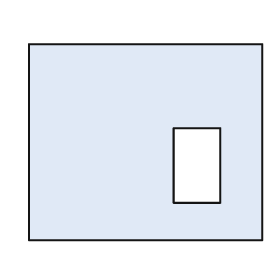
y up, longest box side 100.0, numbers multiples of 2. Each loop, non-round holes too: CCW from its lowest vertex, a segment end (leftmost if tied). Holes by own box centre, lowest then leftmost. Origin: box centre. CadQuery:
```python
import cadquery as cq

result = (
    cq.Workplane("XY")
    .moveTo(-50.0, -42.0)
    .lineTo(50.0, -42.0)
    .lineTo(50.0, 42.0)
    .lineTo(-50.0, 42.0)
    .close()
    .moveTo(12.0, -26.0)
    .lineTo(32.0, -26.0)
    .lineTo(32.0, 6.0)
    .lineTo(12.0, 6.0)
    .close()
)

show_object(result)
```